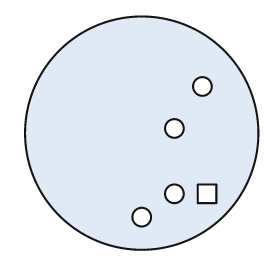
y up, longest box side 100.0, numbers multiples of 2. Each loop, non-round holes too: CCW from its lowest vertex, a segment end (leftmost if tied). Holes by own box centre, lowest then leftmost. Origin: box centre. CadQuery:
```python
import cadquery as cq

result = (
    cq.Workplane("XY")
    .moveTo(0.0, 0.0)
    .circle(50.0)
    .moveTo(0.0, -36.0)
    .circle(4.0)
    .moveTo(14.0, -26.0)
    .circle(4.0)
    .moveTo(24.0, -30.0)
    .lineTo(32.0, -30.0)
    .lineTo(32.0, -22.0)
    .lineTo(24.0, -22.0)
    .close()
    .moveTo(14.0, 2.0)
    .circle(4.0)
    .moveTo(26.0, 20.0)
    .circle(4.0)
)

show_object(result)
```